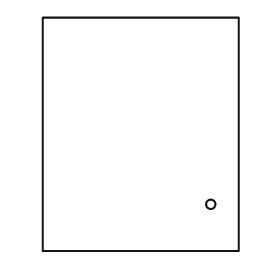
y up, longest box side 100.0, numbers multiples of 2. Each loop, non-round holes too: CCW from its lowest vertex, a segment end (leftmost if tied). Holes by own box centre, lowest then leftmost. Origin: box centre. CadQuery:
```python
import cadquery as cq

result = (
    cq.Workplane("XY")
    .moveTo(-42.0, -50.0)
    .lineTo(42.0, -50.0)
    .lineTo(42.0, 50.0)
    .lineTo(-42.0, 50.0)
    .close()
    .moveTo(30.0, -30.0)
    .circle(2.0)
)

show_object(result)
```